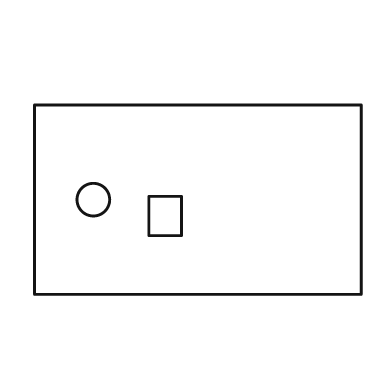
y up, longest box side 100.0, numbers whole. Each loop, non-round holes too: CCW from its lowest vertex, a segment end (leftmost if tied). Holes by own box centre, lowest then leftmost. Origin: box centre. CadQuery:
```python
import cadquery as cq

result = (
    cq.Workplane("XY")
    .moveTo(-50.0, -29.0)
    .lineTo(50.0, -29.0)
    .lineTo(50.0, 29.0)
    .lineTo(-50.0, 29.0)
    .close()
    .moveTo(-15.0, -11.0)
    .lineTo(-5.0, -11.0)
    .lineTo(-5.0, 1.0)
    .lineTo(-15.0, 1.0)
    .close()
    .moveTo(-32.0, 0.0)
    .circle(5.0)
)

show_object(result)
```